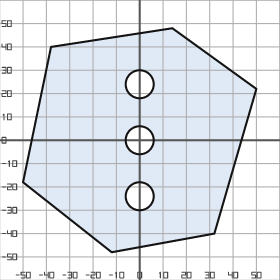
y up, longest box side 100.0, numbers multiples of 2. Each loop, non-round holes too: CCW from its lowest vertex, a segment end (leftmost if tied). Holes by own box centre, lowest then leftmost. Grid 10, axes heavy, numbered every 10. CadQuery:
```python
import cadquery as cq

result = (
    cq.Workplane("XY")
    .moveTo(-12.0, -48.0)
    .lineTo(32.0, -40.0)
    .lineTo(50.0, 22.0)
    .lineTo(14.0, 48.0)
    .lineTo(-38.0, 40.0)
    .lineTo(-50.0, -18.0)
    .close()
    .moveTo(0.0, -24.0)
    .circle(6.0)
    .moveTo(0.0, 0.0)
    .circle(6.0)
    .moveTo(0.0, 24.0)
    .circle(6.0)
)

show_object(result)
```